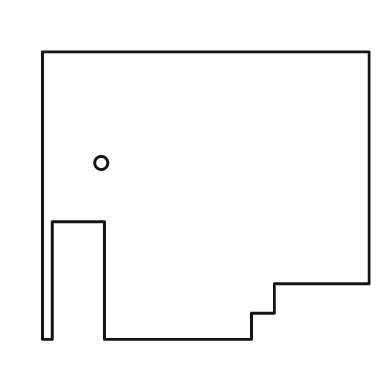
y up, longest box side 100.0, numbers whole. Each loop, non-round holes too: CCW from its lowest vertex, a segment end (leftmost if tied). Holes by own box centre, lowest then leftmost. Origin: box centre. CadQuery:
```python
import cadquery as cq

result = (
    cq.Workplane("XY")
    .moveTo(-50.0, -44.0)
    .lineTo(-47.0, -44.0)
    .lineTo(-47.0, -8.0)
    .lineTo(-31.0, -8.0)
    .lineTo(-31.0, -44.0)
    .lineTo(14.0, -44.0)
    .lineTo(14.0, -36.0)
    .lineTo(21.0, -36.0)
    .lineTo(21.0, -27.0)
    .lineTo(50.0, -27.0)
    .lineTo(50.0, 44.0)
    .lineTo(-50.0, 44.0)
    .close()
    .moveTo(-32.0, 10.0)
    .circle(2.0)
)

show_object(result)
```